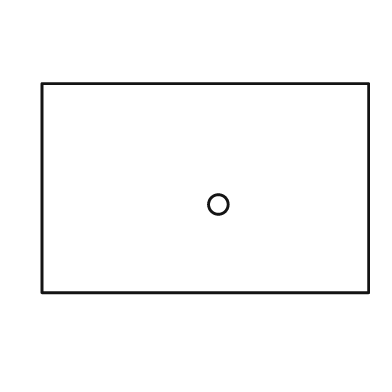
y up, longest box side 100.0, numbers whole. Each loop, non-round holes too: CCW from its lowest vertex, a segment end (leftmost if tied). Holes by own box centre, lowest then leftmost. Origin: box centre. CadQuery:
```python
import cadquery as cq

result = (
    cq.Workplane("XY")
    .moveTo(-50.0, -32.0)
    .lineTo(50.0, -32.0)
    .lineTo(50.0, 32.0)
    .lineTo(-50.0, 32.0)
    .close()
    .moveTo(4.0, -5.0)
    .circle(3.0)
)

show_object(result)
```